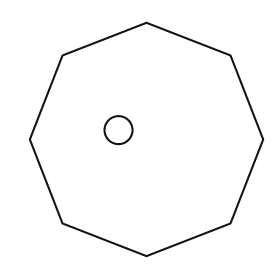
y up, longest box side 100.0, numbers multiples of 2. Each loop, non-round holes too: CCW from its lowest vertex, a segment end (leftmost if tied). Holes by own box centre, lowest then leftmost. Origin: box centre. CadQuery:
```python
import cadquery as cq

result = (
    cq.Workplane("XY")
    .moveTo(0.0, -50.0)
    .lineTo(36.0, -36.0)
    .lineTo(50.0, 0.0)
    .lineTo(36.0, 36.0)
    .lineTo(0.0, 50.0)
    .lineTo(-36.0, 36.0)
    .lineTo(-50.0, 0.0)
    .lineTo(-36.0, -36.0)
    .close()
    .moveTo(-12.0, 4.0)
    .circle(6.0)
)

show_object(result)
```